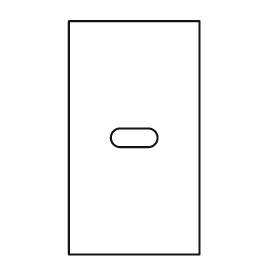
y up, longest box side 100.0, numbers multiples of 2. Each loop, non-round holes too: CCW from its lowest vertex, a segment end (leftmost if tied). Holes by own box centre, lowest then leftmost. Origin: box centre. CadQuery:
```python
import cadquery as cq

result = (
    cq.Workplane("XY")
    .moveTo(-28.0, -50.0)
    .lineTo(28.0, -50.0)
    .lineTo(28.0, 50.0)
    .lineTo(-28.0, 50.0)
    .close()
    .moveTo(-6.0, -4.0)
    .lineTo(6.0, -4.0)
    .threePointArc((10.0, 0.0), (6.0, 4.0))
    .lineTo(-6.0, 4.0)
    .threePointArc((-10.0, 0.0), (-6.0, -4.0))
    .close()
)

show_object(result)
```